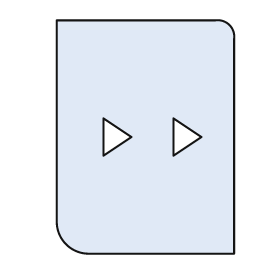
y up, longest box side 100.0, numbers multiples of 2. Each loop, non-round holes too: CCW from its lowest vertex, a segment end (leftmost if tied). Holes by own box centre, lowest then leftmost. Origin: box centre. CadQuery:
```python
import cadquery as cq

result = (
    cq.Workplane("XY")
    .moveTo(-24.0, -50.0)
    .lineTo(38.0, -50.0)
    .lineTo(38.0, 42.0)
    .threePointArc((36.0, 48.0), (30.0, 50.0))
    .lineTo(-38.0, 50.0)
    .lineTo(-38.0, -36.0)
    .threePointArc((-34.0, -46.0), (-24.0, -50.0))
    .close()
    .moveTo(-18.0, -8.0)
    .lineTo(-6.0, 0.0)
    .lineTo(-18.0, 8.0)
    .close()
    .moveTo(12.0, -8.0)
    .lineTo(24.0, 0.0)
    .lineTo(12.0, 8.0)
    .close()
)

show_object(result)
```